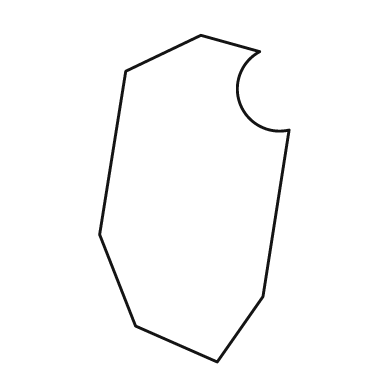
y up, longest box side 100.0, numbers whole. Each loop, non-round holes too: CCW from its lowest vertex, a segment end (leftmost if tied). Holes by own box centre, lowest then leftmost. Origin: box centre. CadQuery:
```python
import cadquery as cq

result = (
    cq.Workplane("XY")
    .moveTo(7.0, -50.0)
    .lineTo(21.0, -30.0)
    .lineTo(29.0, 21.0)
    .threePointArc((14.0, 29.0), (20.0, 45.0))
    .lineTo(2.0, 50.0)
    .lineTo(-21.0, 39.0)
    .lineTo(-29.0, -11.0)
    .lineTo(-18.0, -39.0)
    .close()
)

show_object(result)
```